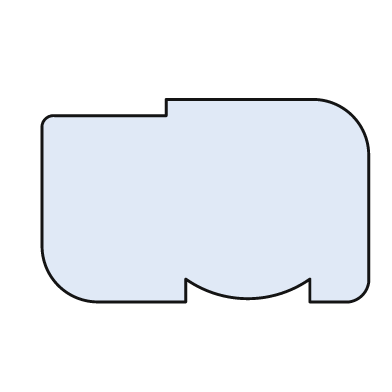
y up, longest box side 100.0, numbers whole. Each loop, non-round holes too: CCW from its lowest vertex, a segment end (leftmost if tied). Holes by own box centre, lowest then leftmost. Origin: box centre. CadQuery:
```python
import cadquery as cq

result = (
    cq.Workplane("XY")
    .moveTo(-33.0, -31.0)
    .lineTo(-6.0, -31.0)
    .lineTo(-6.0, -24.0)
    .threePointArc((13.0, -30.0), (32.0, -24.0))
    .lineTo(32.0, -31.0)
    .lineTo(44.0, -31.0)
    .threePointArc((48.0, -29.0), (50.0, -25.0))
    .lineTo(50.0, 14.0)
    .threePointArc((45.0, 26.0), (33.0, 31.0))
    .lineTo(-12.0, 31.0)
    .lineTo(-12.0, 26.0)
    .lineTo(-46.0, 26.0)
    .threePointArc((-49.0, 25.0), (-50.0, 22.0))
    .lineTo(-50.0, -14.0)
    .threePointArc((-45.0, -26.0), (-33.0, -31.0))
    .close()
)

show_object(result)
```